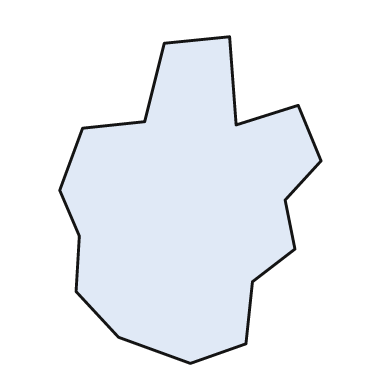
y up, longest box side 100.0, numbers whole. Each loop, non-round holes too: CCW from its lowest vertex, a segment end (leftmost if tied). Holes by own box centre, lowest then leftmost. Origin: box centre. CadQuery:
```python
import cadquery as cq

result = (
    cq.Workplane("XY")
    .moveTo(0.0, -50.0)
    .lineTo(17.0, -44.0)
    .lineTo(19.0, -25.0)
    .lineTo(32.0, -15.0)
    .lineTo(29.0, 0.0)
    .lineTo(40.0, 12.0)
    .lineTo(33.0, 29.0)
    .lineTo(14.0, 23.0)
    .lineTo(12.0, 50.0)
    .lineTo(-8.0, 48.0)
    .lineTo(-14.0, 24.0)
    .lineTo(-33.0, 22.0)
    .lineTo(-40.0, 3.0)
    .lineTo(-34.0, -11.0)
    .lineTo(-35.0, -28.0)
    .lineTo(-22.0, -42.0)
    .close()
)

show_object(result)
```